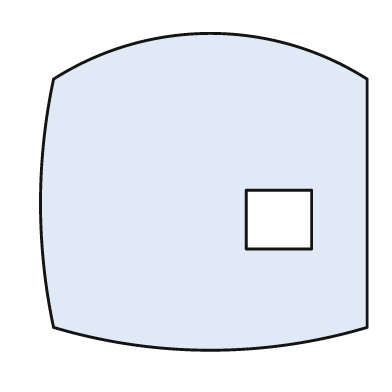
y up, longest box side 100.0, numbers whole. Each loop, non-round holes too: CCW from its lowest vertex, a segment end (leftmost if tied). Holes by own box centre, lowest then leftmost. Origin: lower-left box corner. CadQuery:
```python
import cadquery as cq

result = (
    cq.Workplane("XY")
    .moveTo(4.0, 7.0)
    .threePointArc((52.0, 0.0), (100.0, 7.0))
    .lineTo(100.0, 83.0)
    .threePointArc((52.0, 97.0), (4.0, 83.0))
    .threePointArc((0.0, 45.0), (4.0, 7.0))
    .close()
    .moveTo(63.0, 31.0)
    .lineTo(83.0, 31.0)
    .lineTo(83.0, 49.0)
    .lineTo(63.0, 49.0)
    .close()
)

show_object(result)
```